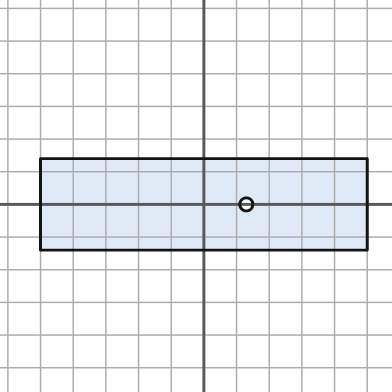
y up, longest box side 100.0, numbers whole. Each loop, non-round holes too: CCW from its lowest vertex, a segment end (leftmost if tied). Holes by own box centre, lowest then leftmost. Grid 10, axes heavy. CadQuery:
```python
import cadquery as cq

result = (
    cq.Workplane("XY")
    .moveTo(-50.0, -14.0)
    .lineTo(50.0, -14.0)
    .lineTo(50.0, 14.0)
    .lineTo(-50.0, 14.0)
    .close()
    .moveTo(13.0, 0.0)
    .circle(2.0)
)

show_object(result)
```